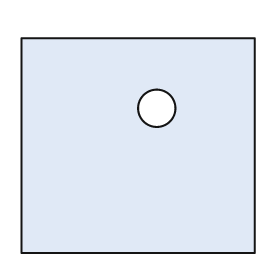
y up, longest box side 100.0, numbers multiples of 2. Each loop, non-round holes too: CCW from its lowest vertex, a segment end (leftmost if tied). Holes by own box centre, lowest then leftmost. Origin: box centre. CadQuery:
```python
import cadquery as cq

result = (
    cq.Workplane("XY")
    .moveTo(-50.0, -46.0)
    .lineTo(50.0, -46.0)
    .lineTo(50.0, 46.0)
    .lineTo(-50.0, 46.0)
    .close()
    .moveTo(8.0, 16.0)
    .circle(8.0)
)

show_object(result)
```